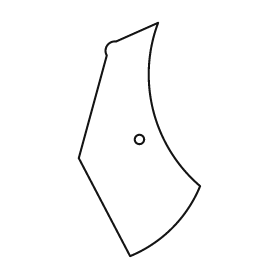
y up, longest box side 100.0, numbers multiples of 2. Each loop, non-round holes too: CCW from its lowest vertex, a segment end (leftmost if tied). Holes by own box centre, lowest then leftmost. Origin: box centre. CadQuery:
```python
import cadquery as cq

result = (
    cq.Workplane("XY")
    .moveTo(-4.0, -50.0)
    .threePointArc((14.0, -38.0), (26.0, -20.0))
    .threePointArc((6.0, 12.0), (8.0, 50.0))
    .lineTo(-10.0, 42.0)
    .threePointArc((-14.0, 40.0), (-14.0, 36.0))
    .lineTo(-26.0, -8.0)
    .close()
    .moveTo(0.0, 0.0)
    .circle(2.0)
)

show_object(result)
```